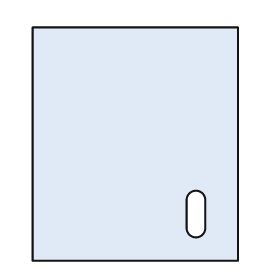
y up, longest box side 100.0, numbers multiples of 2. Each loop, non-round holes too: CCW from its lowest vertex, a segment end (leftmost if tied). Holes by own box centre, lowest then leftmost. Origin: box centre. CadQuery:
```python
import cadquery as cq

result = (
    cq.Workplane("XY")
    .moveTo(-44.0, -50.0)
    .lineTo(44.0, -50.0)
    .lineTo(44.0, 50.0)
    .lineTo(-44.0, 50.0)
    .close()
    .moveTo(22.0, -36.0)
    .threePointArc((26.0, -40.0), (30.0, -36.0))
    .lineTo(30.0, -24.0)
    .threePointArc((26.0, -20.0), (22.0, -24.0))
    .close()
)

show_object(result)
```